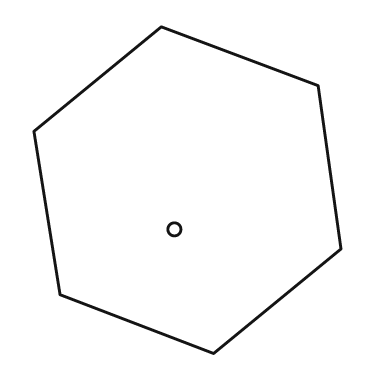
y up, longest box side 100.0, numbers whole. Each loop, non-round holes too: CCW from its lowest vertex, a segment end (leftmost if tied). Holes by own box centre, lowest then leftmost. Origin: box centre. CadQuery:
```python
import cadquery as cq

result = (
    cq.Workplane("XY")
    .moveTo(8.0, -50.0)
    .lineTo(47.0, -18.0)
    .lineTo(40.0, 32.0)
    .lineTo(-8.0, 50.0)
    .lineTo(-47.0, 18.0)
    .lineTo(-39.0, -32.0)
    .close()
    .moveTo(-4.0, -12.0)
    .circle(2.0)
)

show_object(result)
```